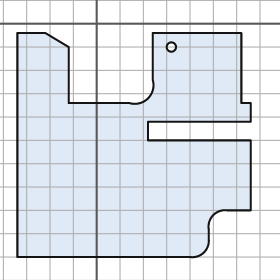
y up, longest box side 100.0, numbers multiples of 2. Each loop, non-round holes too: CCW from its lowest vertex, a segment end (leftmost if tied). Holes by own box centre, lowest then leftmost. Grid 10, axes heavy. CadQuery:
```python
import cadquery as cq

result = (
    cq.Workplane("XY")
    .moveTo(-34.0, -100.0)
    .lineTo(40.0, -100.0)
    .threePointArc((46.0, -98.0), (48.0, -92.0))
    .lineTo(48.0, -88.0)
    .threePointArc((50.0, -82.0), (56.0, -80.0))
    .lineTo(66.0, -80.0)
    .lineTo(66.0, -50.0)
    .lineTo(22.0, -50.0)
    .lineTo(22.0, -42.0)
    .lineTo(66.0, -42.0)
    .lineTo(66.0, -34.0)
    .lineTo(62.0, -34.0)
    .lineTo(62.0, -4.0)
    .lineTo(24.0, -4.0)
    .lineTo(24.0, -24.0)
    .threePointArc((22.0, -32.0), (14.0, -34.0))
    .lineTo(-12.0, -34.0)
    .lineTo(-12.0, -10.0)
    .lineTo(-22.0, -4.0)
    .lineTo(-34.0, -4.0)
    .close()
    .moveTo(32.0, -10.0)
    .circle(2.0)
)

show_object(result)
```